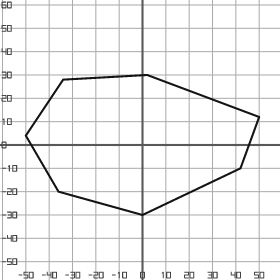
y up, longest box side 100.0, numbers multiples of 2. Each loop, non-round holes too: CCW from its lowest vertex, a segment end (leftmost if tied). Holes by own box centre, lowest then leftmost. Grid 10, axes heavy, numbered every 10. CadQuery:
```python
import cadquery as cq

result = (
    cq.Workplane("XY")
    .moveTo(0.0, -30.0)
    .lineTo(42.0, -10.0)
    .lineTo(50.0, 12.0)
    .lineTo(2.0, 30.0)
    .lineTo(-34.0, 28.0)
    .lineTo(-50.0, 4.0)
    .lineTo(-36.0, -20.0)
    .close()
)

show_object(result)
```